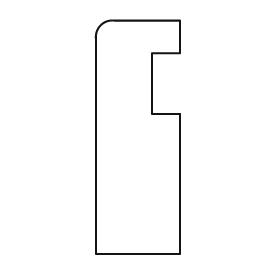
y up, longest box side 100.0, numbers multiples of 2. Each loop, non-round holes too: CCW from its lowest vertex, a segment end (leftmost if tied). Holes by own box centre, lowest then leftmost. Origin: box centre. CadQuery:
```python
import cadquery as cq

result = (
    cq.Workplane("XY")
    .moveTo(-18.0, -50.0)
    .lineTo(18.0, -50.0)
    .lineTo(18.0, 10.0)
    .lineTo(6.0, 10.0)
    .lineTo(6.0, 36.0)
    .lineTo(18.0, 36.0)
    .lineTo(18.0, 50.0)
    .lineTo(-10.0, 50.0)
    .threePointArc((-16.0, 48.0), (-18.0, 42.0))
    .close()
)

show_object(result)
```